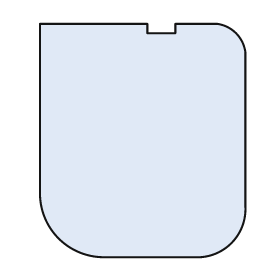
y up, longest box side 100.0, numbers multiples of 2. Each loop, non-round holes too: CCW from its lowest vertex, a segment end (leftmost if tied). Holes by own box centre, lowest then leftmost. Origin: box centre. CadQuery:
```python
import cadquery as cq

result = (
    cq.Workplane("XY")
    .moveTo(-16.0, -50.0)
    .lineTo(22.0, -50.0)
    .threePointArc((38.0, -44.0), (44.0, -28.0))
    .lineTo(44.0, 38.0)
    .threePointArc((40.0, 46.0), (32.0, 50.0))
    .lineTo(14.0, 50.0)
    .lineTo(14.0, 46.0)
    .lineTo(2.0, 46.0)
    .lineTo(2.0, 50.0)
    .lineTo(-44.0, 50.0)
    .lineTo(-44.0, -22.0)
    .threePointArc((-36.0, -42.0), (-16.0, -50.0))
    .close()
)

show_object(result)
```